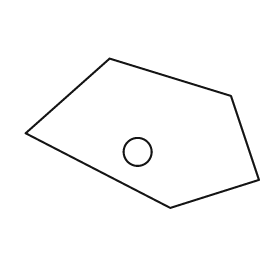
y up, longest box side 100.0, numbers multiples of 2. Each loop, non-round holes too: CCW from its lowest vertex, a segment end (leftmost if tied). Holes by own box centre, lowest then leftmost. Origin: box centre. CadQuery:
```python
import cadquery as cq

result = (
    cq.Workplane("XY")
    .moveTo(12.0, -32.0)
    .lineTo(50.0, -20.0)
    .lineTo(38.0, 16.0)
    .lineTo(-14.0, 32.0)
    .lineTo(-50.0, 0.0)
    .close()
    .moveTo(-2.0, -8.0)
    .circle(6.0)
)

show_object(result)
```